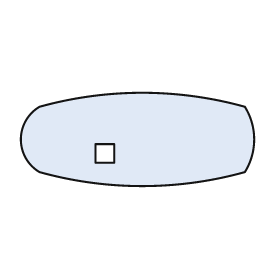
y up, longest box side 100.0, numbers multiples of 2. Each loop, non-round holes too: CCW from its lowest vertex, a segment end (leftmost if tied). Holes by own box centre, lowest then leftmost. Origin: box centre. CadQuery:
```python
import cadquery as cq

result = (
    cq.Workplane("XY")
    .moveTo(-42.0, -14.0)
    .threePointArc((2.0, -20.0), (46.0, -14.0))
    .threePointArc((50.0, 0.0), (46.0, 14.0))
    .threePointArc((2.0, 20.0), (-42.0, 14.0))
    .threePointArc((-50.0, 0.0), (-42.0, -14.0))
    .close()
    .moveTo(-18.0, -10.0)
    .lineTo(-10.0, -10.0)
    .lineTo(-10.0, -2.0)
    .lineTo(-18.0, -2.0)
    .close()
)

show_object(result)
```